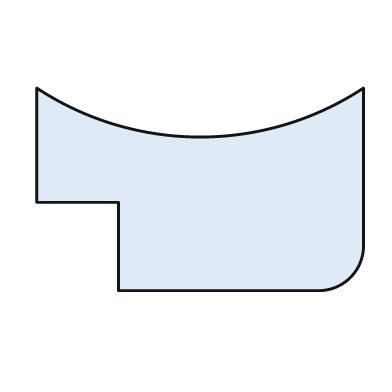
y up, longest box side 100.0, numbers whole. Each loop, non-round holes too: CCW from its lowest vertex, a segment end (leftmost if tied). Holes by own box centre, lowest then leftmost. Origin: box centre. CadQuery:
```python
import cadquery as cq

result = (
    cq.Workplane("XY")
    .moveTo(-25.0, -31.0)
    .lineTo(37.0, -31.0)
    .threePointArc((46.0, -27.0), (50.0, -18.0))
    .lineTo(50.0, 31.0)
    .threePointArc((0.0, 16.0), (-50.0, 31.0))
    .lineTo(-50.0, -4.0)
    .lineTo(-25.0, -4.0)
    .close()
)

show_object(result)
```